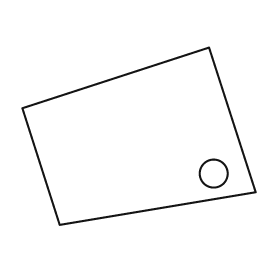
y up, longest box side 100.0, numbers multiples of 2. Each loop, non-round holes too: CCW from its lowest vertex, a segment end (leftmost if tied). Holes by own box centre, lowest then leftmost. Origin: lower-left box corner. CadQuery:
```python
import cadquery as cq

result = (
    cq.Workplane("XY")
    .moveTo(16.0, 0.0)
    .lineTo(100.0, 14.0)
    .lineTo(80.0, 76.0)
    .lineTo(0.0, 50.0)
    .close()
    .moveTo(82.0, 22.0)
    .circle(6.0)
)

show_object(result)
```